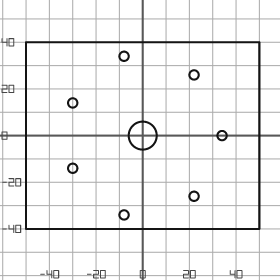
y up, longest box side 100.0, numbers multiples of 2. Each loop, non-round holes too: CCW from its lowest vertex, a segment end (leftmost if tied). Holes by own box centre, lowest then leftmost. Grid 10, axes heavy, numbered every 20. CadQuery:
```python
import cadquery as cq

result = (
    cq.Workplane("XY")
    .moveTo(-50.0, -40.0)
    .lineTo(50.0, -40.0)
    .lineTo(50.0, 40.0)
    .lineTo(-50.0, 40.0)
    .close()
    .moveTo(-8.0, -34.0)
    .circle(2.0)
    .moveTo(22.0, -26.0)
    .circle(2.0)
    .moveTo(-30.0, -14.0)
    .circle(2.0)
    .moveTo(0.0, 0.0)
    .circle(6.0)
    .moveTo(34.0, 0.0)
    .circle(2.0)
    .moveTo(-30.0, 14.0)
    .circle(2.0)
    .moveTo(22.0, 26.0)
    .circle(2.0)
    .moveTo(-8.0, 34.0)
    .circle(2.0)
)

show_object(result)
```